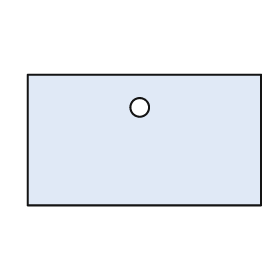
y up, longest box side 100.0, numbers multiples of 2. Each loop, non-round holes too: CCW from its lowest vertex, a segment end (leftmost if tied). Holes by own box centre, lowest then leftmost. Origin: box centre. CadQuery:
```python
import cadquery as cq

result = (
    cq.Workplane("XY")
    .moveTo(-50.0, -28.0)
    .lineTo(50.0, -28.0)
    .lineTo(50.0, 28.0)
    .lineTo(-50.0, 28.0)
    .close()
    .moveTo(-2.0, 14.0)
    .circle(4.0)
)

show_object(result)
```